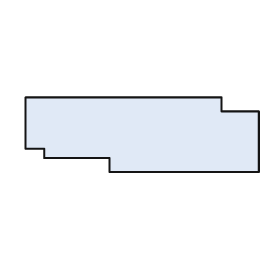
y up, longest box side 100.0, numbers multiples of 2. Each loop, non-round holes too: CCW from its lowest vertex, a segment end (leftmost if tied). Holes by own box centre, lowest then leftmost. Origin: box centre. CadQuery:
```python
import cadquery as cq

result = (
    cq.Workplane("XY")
    .moveTo(-14.0, -16.0)
    .lineTo(50.0, -16.0)
    .lineTo(50.0, 10.0)
    .lineTo(34.0, 10.0)
    .lineTo(34.0, 16.0)
    .lineTo(-50.0, 16.0)
    .lineTo(-50.0, -6.0)
    .lineTo(-42.0, -6.0)
    .lineTo(-42.0, -10.0)
    .lineTo(-14.0, -10.0)
    .close()
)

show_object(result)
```